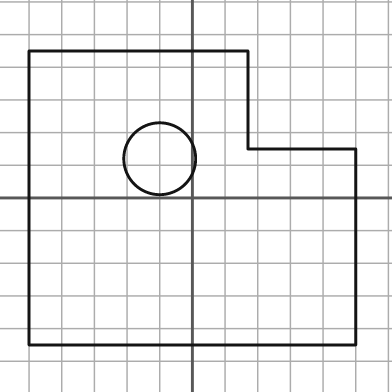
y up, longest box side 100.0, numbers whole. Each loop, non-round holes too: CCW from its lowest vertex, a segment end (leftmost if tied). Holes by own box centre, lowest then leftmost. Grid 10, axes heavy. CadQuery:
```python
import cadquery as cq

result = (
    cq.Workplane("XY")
    .moveTo(-50.0, -45.0)
    .lineTo(50.0, -45.0)
    .lineTo(50.0, 15.0)
    .lineTo(17.0, 15.0)
    .lineTo(17.0, 45.0)
    .lineTo(-50.0, 45.0)
    .close()
    .moveTo(-10.0, 12.0)
    .circle(11.0)
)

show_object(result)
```